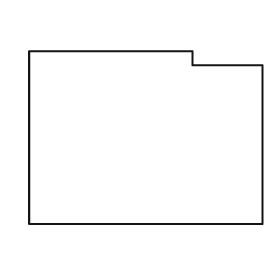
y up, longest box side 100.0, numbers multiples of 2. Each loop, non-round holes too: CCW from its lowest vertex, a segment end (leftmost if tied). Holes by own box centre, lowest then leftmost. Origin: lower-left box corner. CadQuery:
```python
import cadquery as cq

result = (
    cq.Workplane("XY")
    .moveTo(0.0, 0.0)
    .lineTo(100.0, 0.0)
    .lineTo(100.0, 68.0)
    .lineTo(70.0, 68.0)
    .lineTo(70.0, 74.0)
    .lineTo(0.0, 74.0)
    .close()
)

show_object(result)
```